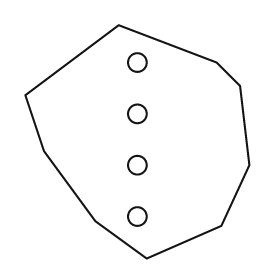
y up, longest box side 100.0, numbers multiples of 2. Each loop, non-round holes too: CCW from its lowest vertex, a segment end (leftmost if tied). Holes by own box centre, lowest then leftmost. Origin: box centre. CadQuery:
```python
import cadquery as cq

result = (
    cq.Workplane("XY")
    .moveTo(4.0, -50.0)
    .lineTo(36.0, -36.0)
    .lineTo(48.0, -10.0)
    .lineTo(44.0, 24.0)
    .lineTo(34.0, 34.0)
    .lineTo(-8.0, 50.0)
    .lineTo(-48.0, 20.0)
    .lineTo(-40.0, -4.0)
    .lineTo(-18.0, -34.0)
    .close()
    .moveTo(0.0, -32.0)
    .circle(4.0)
    .moveTo(0.0, -10.0)
    .circle(4.0)
    .moveTo(0.0, 12.0)
    .circle(4.0)
    .moveTo(0.0, 34.0)
    .circle(4.0)
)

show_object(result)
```